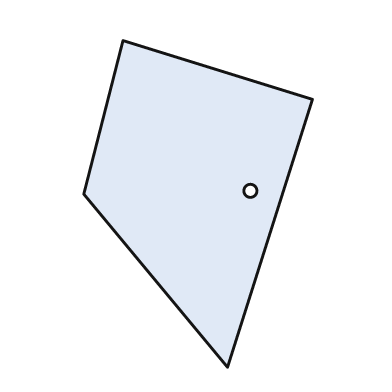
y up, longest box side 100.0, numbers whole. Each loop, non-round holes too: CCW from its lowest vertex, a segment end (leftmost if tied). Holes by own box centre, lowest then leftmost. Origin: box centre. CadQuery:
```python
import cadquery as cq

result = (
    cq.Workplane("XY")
    .moveTo(9.0, -50.0)
    .lineTo(35.0, 32.0)
    .lineTo(-23.0, 50.0)
    .lineTo(-35.0, 3.0)
    .close()
    .moveTo(16.0, 4.0)
    .circle(2.0)
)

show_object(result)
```